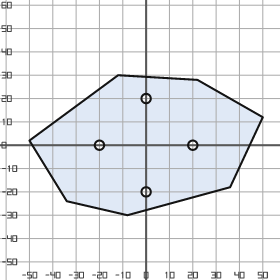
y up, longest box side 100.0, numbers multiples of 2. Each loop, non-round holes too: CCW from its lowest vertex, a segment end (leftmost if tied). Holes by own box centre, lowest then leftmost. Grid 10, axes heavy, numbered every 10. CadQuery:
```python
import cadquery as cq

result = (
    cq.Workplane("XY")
    .moveTo(-8.0, -30.0)
    .lineTo(36.0, -18.0)
    .lineTo(50.0, 12.0)
    .lineTo(22.0, 28.0)
    .lineTo(-12.0, 30.0)
    .lineTo(-50.0, 2.0)
    .lineTo(-34.0, -24.0)
    .close()
    .moveTo(0.0, -20.0)
    .circle(2.0)
    .moveTo(-20.0, 0.0)
    .circle(2.0)
    .moveTo(20.0, 0.0)
    .circle(2.0)
    .moveTo(0.0, 20.0)
    .circle(2.0)
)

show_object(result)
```